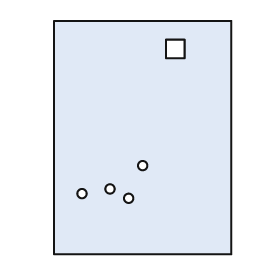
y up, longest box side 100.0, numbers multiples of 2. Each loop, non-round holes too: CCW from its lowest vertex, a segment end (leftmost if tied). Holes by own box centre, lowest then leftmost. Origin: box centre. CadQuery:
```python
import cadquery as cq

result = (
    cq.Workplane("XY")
    .moveTo(-38.0, -50.0)
    .lineTo(38.0, -50.0)
    .lineTo(38.0, 50.0)
    .lineTo(-38.0, 50.0)
    .close()
    .moveTo(-6.0, -26.0)
    .circle(2.0)
    .moveTo(-26.0, -24.0)
    .circle(2.0)
    .moveTo(-14.0, -22.0)
    .circle(2.0)
    .moveTo(0.0, -12.0)
    .circle(2.0)
    .moveTo(10.0, 34.0)
    .lineTo(18.0, 34.0)
    .lineTo(18.0, 42.0)
    .lineTo(10.0, 42.0)
    .close()
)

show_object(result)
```